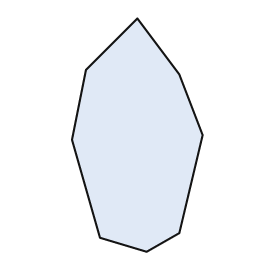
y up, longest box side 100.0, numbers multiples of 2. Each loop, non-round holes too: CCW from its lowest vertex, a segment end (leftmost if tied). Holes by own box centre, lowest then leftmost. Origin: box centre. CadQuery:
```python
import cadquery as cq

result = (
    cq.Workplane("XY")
    .moveTo(4.0, -50.0)
    .lineTo(18.0, -42.0)
    .lineTo(28.0, 0.0)
    .lineTo(18.0, 26.0)
    .lineTo(0.0, 50.0)
    .lineTo(-22.0, 28.0)
    .lineTo(-28.0, -2.0)
    .lineTo(-16.0, -44.0)
    .close()
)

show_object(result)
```